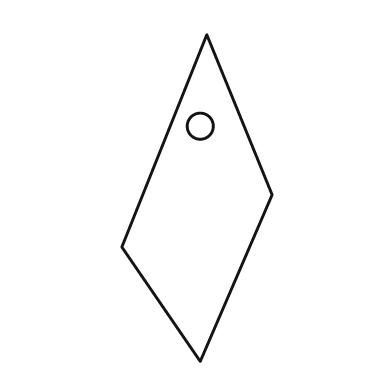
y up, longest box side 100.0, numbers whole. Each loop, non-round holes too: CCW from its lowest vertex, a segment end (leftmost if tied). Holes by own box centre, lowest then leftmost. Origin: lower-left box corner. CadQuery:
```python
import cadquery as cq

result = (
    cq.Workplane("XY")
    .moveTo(24.0, 0.0)
    .lineTo(46.0, 51.0)
    .lineTo(26.0, 100.0)
    .lineTo(0.0, 35.0)
    .close()
    .moveTo(24.0, 72.0)
    .circle(4.0)
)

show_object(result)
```